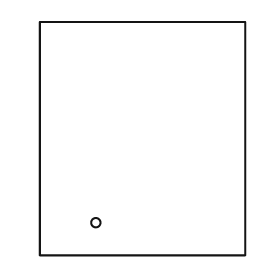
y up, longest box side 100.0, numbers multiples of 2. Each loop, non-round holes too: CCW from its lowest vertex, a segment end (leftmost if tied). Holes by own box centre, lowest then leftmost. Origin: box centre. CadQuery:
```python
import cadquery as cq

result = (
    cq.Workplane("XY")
    .moveTo(-44.0, -50.0)
    .lineTo(44.0, -50.0)
    .lineTo(44.0, 50.0)
    .lineTo(-44.0, 50.0)
    .close()
    .moveTo(-20.0, -36.0)
    .circle(2.0)
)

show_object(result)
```